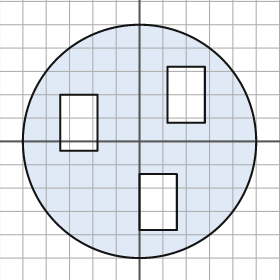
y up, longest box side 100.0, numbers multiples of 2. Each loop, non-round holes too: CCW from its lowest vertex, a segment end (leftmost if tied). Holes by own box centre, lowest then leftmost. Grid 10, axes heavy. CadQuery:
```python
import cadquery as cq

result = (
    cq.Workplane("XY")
    .moveTo(0.0, 0.0)
    .circle(50.0)
    .moveTo(0.0, -38.0)
    .lineTo(16.0, -38.0)
    .lineTo(16.0, -14.0)
    .lineTo(0.0, -14.0)
    .close()
    .moveTo(-34.0, -4.0)
    .lineTo(-18.0, -4.0)
    .lineTo(-18.0, 20.0)
    .lineTo(-34.0, 20.0)
    .close()
    .moveTo(12.0, 8.0)
    .lineTo(28.0, 8.0)
    .lineTo(28.0, 32.0)
    .lineTo(12.0, 32.0)
    .close()
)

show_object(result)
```